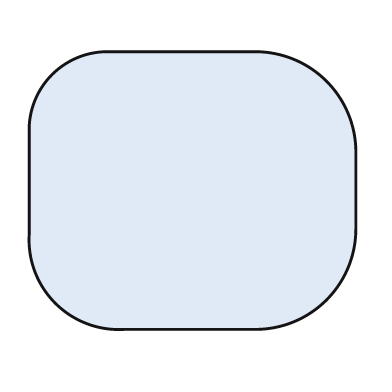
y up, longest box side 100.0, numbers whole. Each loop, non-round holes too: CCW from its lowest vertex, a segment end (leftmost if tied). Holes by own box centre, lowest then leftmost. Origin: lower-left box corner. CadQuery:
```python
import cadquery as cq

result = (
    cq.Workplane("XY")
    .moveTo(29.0, 0.0)
    .lineTo(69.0, 0.0)
    .threePointArc((91.0, 9.0), (100.0, 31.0))
    .lineTo(100.0, 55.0)
    .threePointArc((91.0, 76.0), (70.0, 85.0))
    .lineTo(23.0, 85.0)
    .threePointArc((7.0, 78.0), (0.0, 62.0))
    .lineTo(0.0, 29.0)
    .threePointArc((8.0, 8.0), (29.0, 0.0))
    .close()
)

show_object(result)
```